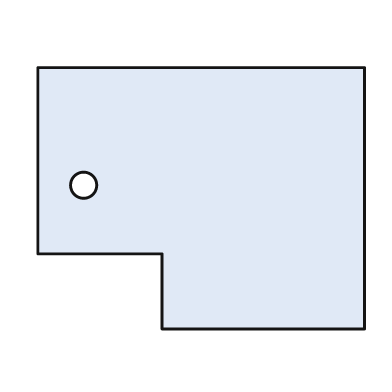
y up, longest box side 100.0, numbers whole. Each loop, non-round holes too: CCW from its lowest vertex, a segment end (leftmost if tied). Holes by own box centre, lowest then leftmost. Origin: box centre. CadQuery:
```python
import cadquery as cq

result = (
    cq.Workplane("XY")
    .moveTo(-12.0, -40.0)
    .lineTo(50.0, -40.0)
    .lineTo(50.0, 40.0)
    .lineTo(-50.0, 40.0)
    .lineTo(-50.0, -17.0)
    .lineTo(-12.0, -17.0)
    .close()
    .moveTo(-36.0, 4.0)
    .circle(4.0)
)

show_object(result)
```